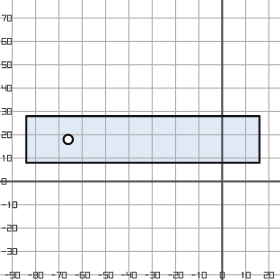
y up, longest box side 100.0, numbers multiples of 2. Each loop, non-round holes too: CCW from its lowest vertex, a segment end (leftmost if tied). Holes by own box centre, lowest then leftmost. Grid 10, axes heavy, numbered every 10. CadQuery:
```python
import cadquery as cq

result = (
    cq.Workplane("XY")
    .moveTo(-84.0, 8.0)
    .lineTo(16.0, 8.0)
    .lineTo(16.0, 28.0)
    .lineTo(-84.0, 28.0)
    .close()
    .moveTo(-66.0, 18.0)
    .circle(2.0)
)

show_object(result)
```